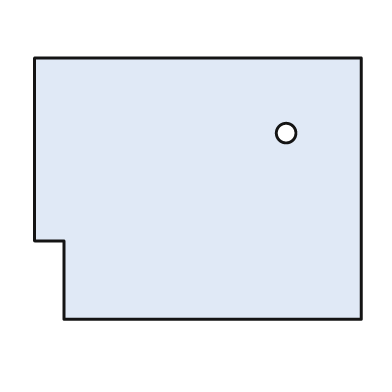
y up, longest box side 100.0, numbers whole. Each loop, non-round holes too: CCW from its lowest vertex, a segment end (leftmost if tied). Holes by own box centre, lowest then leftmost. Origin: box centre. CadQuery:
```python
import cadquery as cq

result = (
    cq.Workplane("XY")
    .moveTo(-41.0, -40.0)
    .lineTo(50.0, -40.0)
    .lineTo(50.0, 40.0)
    .lineTo(-50.0, 40.0)
    .lineTo(-50.0, -16.0)
    .lineTo(-41.0, -16.0)
    .close()
    .moveTo(27.0, 17.0)
    .circle(3.0)
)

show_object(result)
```